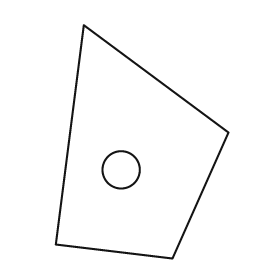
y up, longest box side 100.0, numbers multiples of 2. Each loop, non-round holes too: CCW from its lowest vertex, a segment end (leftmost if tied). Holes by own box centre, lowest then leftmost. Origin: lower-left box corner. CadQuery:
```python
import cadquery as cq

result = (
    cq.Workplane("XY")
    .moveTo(50.0, 0.0)
    .lineTo(74.0, 54.0)
    .lineTo(12.0, 100.0)
    .lineTo(0.0, 6.0)
    .close()
    .moveTo(28.0, 38.0)
    .circle(8.0)
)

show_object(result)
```